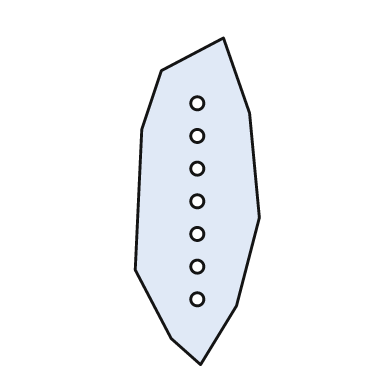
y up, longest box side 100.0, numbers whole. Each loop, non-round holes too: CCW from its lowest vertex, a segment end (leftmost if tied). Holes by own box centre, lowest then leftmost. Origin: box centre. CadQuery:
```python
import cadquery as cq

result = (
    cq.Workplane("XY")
    .moveTo(1.0, -50.0)
    .lineTo(12.0, -32.0)
    .lineTo(19.0, -5.0)
    .lineTo(16.0, 27.0)
    .lineTo(8.0, 50.0)
    .lineTo(-11.0, 40.0)
    .lineTo(-17.0, 22.0)
    .lineTo(-19.0, -21.0)
    .lineTo(-8.0, -42.0)
    .close()
    .moveTo(0.0, -30.0)
    .circle(2.0)
    .moveTo(0.0, -20.0)
    .circle(2.0)
    .moveTo(0.0, -10.0)
    .circle(2.0)
    .moveTo(0.0, 0.0)
    .circle(2.0)
    .moveTo(0.0, 10.0)
    .circle(2.0)
    .moveTo(0.0, 20.0)
    .circle(2.0)
    .moveTo(0.0, 30.0)
    .circle(2.0)
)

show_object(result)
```